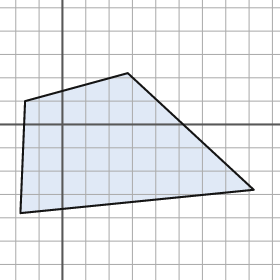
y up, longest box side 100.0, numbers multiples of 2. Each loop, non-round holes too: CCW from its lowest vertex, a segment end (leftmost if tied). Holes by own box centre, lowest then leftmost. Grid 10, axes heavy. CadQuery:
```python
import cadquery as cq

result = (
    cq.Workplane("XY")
    .moveTo(-18.0, -38.0)
    .lineTo(82.0, -28.0)
    .lineTo(28.0, 22.0)
    .lineTo(-16.0, 10.0)
    .close()
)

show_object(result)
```